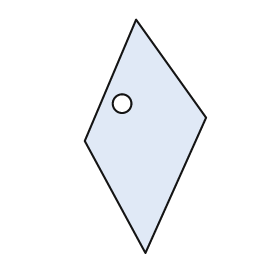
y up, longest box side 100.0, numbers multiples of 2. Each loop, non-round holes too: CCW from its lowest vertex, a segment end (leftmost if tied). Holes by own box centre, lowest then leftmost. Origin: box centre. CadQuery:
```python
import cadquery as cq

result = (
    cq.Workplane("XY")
    .moveTo(0.0, -50.0)
    .lineTo(26.0, 8.0)
    .lineTo(-4.0, 50.0)
    .lineTo(-26.0, -2.0)
    .close()
    .moveTo(-10.0, 14.0)
    .circle(4.0)
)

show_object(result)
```